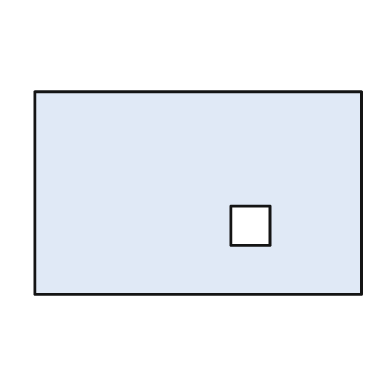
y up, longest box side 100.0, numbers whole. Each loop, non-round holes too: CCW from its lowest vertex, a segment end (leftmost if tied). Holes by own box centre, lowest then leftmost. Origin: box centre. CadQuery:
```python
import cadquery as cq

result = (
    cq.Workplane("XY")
    .moveTo(-50.0, -31.0)
    .lineTo(50.0, -31.0)
    .lineTo(50.0, 31.0)
    .lineTo(-50.0, 31.0)
    .close()
    .moveTo(10.0, -16.0)
    .lineTo(22.0, -16.0)
    .lineTo(22.0, -4.0)
    .lineTo(10.0, -4.0)
    .close()
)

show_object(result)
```